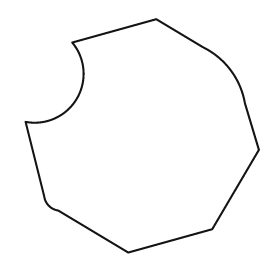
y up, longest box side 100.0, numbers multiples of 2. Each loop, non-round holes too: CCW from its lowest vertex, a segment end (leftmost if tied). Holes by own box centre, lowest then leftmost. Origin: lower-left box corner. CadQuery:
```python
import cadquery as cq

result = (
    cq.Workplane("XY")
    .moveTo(44.0, 0.0)
    .lineTo(80.0, 10.0)
    .lineTo(100.0, 44.0)
    .lineTo(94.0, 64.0)
    .threePointArc((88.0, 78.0), (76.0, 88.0))
    .lineTo(56.0, 100.0)
    .lineTo(20.0, 90.0)
    .threePointArc((22.0, 66.0), (0.0, 56.0))
    .lineTo(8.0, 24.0)
    .threePointArc((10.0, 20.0), (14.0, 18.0))
    .close()
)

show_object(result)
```